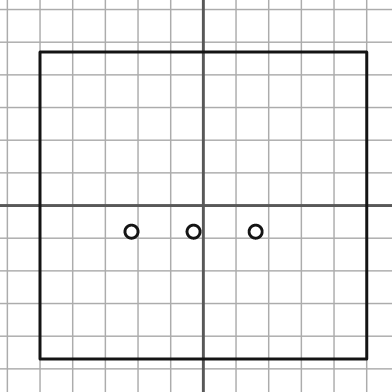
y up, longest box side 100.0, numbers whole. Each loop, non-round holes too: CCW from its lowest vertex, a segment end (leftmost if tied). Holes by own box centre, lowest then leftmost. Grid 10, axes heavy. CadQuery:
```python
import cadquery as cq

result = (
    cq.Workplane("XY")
    .moveTo(-50.0, -47.0)
    .lineTo(50.0, -47.0)
    .lineTo(50.0, 47.0)
    .lineTo(-50.0, 47.0)
    .close()
    .moveTo(-22.0, -8.0)
    .circle(2.0)
    .moveTo(-3.0, -8.0)
    .circle(2.0)
    .moveTo(16.0, -8.0)
    .circle(2.0)
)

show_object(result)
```